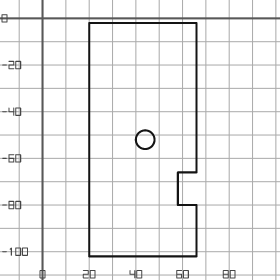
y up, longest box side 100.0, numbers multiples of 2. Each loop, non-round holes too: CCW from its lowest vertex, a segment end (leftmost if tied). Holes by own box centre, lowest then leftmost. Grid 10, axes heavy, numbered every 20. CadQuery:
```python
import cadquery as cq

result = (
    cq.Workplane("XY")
    .moveTo(20.0, -102.0)
    .lineTo(66.0, -102.0)
    .lineTo(66.0, -80.0)
    .lineTo(58.0, -80.0)
    .lineTo(58.0, -66.0)
    .lineTo(66.0, -66.0)
    .lineTo(66.0, -2.0)
    .lineTo(20.0, -2.0)
    .close()
    .moveTo(44.0, -52.0)
    .circle(4.0)
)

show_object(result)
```